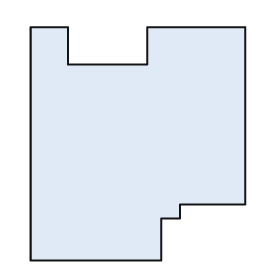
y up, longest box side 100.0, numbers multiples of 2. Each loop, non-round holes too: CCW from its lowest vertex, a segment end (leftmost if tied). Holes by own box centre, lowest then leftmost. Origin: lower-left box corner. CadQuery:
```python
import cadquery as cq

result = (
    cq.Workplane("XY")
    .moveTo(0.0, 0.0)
    .lineTo(56.0, 0.0)
    .lineTo(56.0, 18.0)
    .lineTo(64.0, 18.0)
    .lineTo(64.0, 24.0)
    .lineTo(92.0, 24.0)
    .lineTo(92.0, 100.0)
    .lineTo(50.0, 100.0)
    .lineTo(50.0, 84.0)
    .lineTo(16.0, 84.0)
    .lineTo(16.0, 100.0)
    .lineTo(0.0, 100.0)
    .close()
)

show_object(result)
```